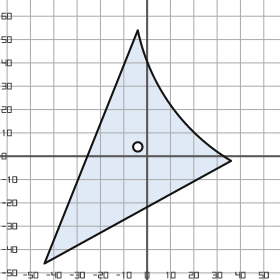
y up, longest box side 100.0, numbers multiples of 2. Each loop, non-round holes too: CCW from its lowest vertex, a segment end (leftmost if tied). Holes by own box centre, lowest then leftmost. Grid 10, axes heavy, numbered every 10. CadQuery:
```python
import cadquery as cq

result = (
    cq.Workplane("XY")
    .moveTo(-44.0, -46.0)
    .lineTo(36.0, -2.0)
    .threePointArc((10.0, 22.0), (-4.0, 54.0))
    .close()
    .moveTo(-4.0, 4.0)
    .circle(2.0)
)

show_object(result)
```